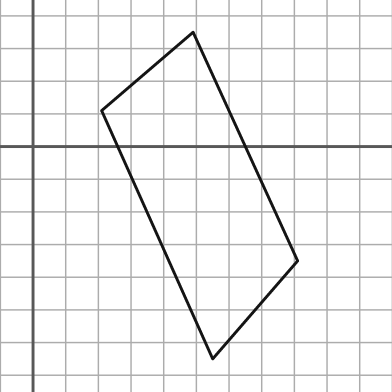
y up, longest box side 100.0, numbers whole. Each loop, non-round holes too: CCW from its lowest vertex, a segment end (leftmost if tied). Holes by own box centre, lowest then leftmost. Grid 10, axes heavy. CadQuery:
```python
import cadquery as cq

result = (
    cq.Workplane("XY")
    .moveTo(55.0, -65.0)
    .lineTo(81.0, -35.0)
    .lineTo(49.0, 35.0)
    .lineTo(21.0, 11.0)
    .close()
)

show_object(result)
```